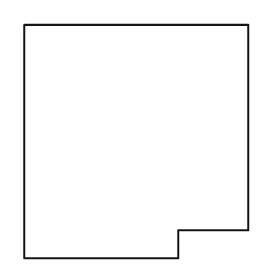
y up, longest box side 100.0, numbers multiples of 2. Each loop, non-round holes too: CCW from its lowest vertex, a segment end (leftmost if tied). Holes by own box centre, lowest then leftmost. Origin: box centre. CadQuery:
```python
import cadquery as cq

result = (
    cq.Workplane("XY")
    .moveTo(-48.0, -50.0)
    .lineTo(18.0, -50.0)
    .lineTo(18.0, -38.0)
    .lineTo(48.0, -38.0)
    .lineTo(48.0, 50.0)
    .lineTo(-48.0, 50.0)
    .close()
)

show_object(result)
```